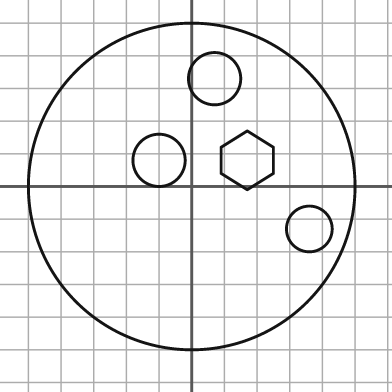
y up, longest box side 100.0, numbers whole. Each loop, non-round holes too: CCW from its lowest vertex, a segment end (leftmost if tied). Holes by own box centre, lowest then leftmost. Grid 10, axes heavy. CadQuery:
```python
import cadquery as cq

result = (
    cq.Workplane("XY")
    .moveTo(0.0, 0.0)
    .circle(50.0)
    .moveTo(36.0, -13.0)
    .circle(7.0)
    .moveTo(-10.0, 8.0)
    .circle(8.0)
    .moveTo(17.0, -1.0)
    .lineTo(25.0, 4.0)
    .lineTo(25.0, 12.0)
    .lineTo(17.0, 17.0)
    .lineTo(9.0, 12.0)
    .lineTo(9.0, 4.0)
    .close()
    .moveTo(7.0, 33.0)
    .circle(8.0)
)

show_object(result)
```